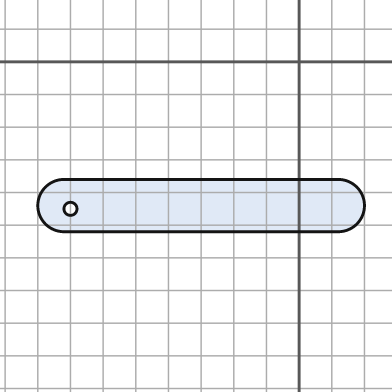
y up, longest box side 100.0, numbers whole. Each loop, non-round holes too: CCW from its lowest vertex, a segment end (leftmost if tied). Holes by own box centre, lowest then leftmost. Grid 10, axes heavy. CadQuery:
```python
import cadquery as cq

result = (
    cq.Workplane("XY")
    .moveTo(-72.0, -52.0)
    .lineTo(12.0, -52.0)
    .threePointArc((20.0, -44.0), (12.0, -36.0))
    .lineTo(-72.0, -36.0)
    .threePointArc((-80.0, -44.0), (-72.0, -52.0))
    .close()
    .moveTo(-70.0, -45.0)
    .circle(2.0)
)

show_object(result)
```